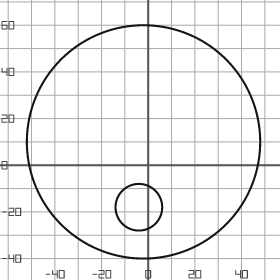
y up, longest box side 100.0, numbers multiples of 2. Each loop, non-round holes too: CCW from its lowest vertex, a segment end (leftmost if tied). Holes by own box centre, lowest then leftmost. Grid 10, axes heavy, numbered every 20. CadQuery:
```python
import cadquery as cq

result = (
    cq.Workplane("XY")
    .moveTo(-2.0, 10.0)
    .circle(50.0)
    .moveTo(-4.0, -18.0)
    .circle(10.0)
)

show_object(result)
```